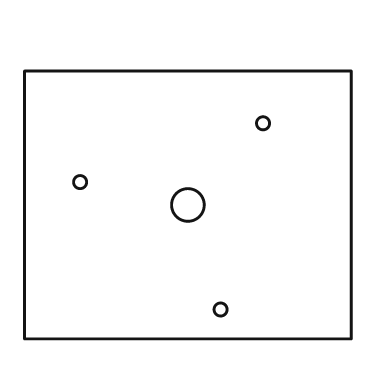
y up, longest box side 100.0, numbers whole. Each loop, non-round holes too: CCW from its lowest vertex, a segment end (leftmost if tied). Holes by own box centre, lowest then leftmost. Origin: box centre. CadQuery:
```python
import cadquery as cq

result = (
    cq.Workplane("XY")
    .moveTo(-50.0, -41.0)
    .lineTo(50.0, -41.0)
    .lineTo(50.0, 41.0)
    .lineTo(-50.0, 41.0)
    .close()
    .moveTo(10.0, -32.0)
    .circle(2.0)
    .moveTo(0.0, 0.0)
    .circle(5.0)
    .moveTo(-33.0, 7.0)
    .circle(2.0)
    .moveTo(23.0, 25.0)
    .circle(2.0)
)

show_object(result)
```